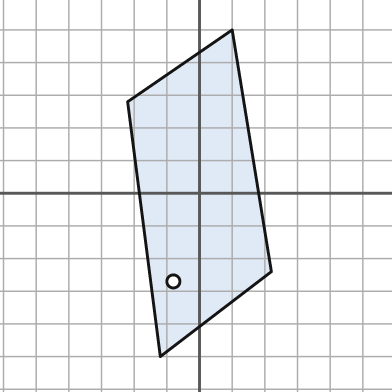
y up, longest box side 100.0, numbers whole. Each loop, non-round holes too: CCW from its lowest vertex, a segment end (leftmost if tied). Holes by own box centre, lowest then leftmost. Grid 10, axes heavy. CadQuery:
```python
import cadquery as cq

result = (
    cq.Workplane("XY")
    .moveTo(-12.0, -50.0)
    .lineTo(22.0, -24.0)
    .lineTo(10.0, 50.0)
    .lineTo(-22.0, 28.0)
    .close()
    .moveTo(-8.0, -27.0)
    .circle(2.0)
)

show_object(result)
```